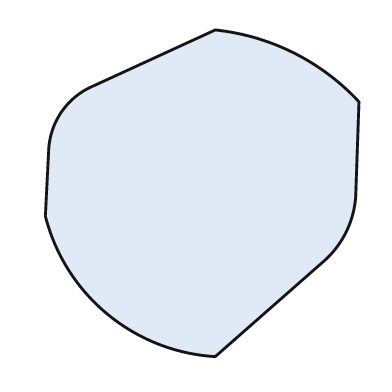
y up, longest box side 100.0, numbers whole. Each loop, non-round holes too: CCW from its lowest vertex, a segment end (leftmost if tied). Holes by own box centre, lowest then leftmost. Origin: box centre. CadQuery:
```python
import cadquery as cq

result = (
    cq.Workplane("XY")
    .moveTo(4.0, -50.0)
    .lineTo(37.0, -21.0)
    .threePointArc((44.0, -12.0), (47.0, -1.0))
    .lineTo(48.0, 28.0)
    .threePointArc((28.0, 43.0), (4.0, 50.0))
    .lineTo(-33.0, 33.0)
    .threePointArc((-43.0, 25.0), (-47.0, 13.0))
    .lineTo(-48.0, -7.0)
    .threePointArc((-29.0, -37.0), (4.0, -50.0))
    .close()
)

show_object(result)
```